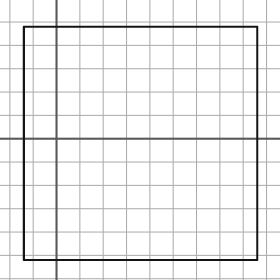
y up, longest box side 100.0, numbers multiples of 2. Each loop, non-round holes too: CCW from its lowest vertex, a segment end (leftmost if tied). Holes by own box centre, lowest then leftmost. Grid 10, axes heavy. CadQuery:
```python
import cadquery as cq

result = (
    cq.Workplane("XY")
    .moveTo(-14.0, -52.0)
    .lineTo(86.0, -52.0)
    .lineTo(86.0, 48.0)
    .lineTo(-14.0, 48.0)
    .close()
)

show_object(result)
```